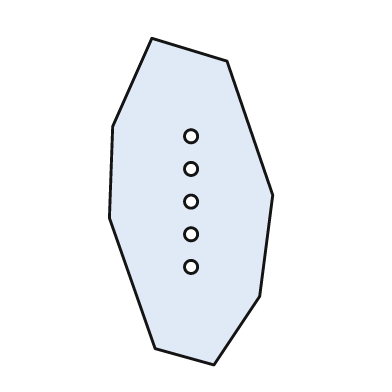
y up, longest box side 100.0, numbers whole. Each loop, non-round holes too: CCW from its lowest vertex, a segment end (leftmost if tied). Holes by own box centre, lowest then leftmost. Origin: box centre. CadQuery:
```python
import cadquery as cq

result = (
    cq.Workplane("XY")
    .moveTo(7.0, -50.0)
    .lineTo(21.0, -29.0)
    .lineTo(25.0, 2.0)
    .lineTo(11.0, 43.0)
    .lineTo(-12.0, 50.0)
    .lineTo(-24.0, 23.0)
    .lineTo(-25.0, -5.0)
    .lineTo(-11.0, -45.0)
    .close()
    .moveTo(0.0, -20.0)
    .circle(2.0)
    .moveTo(0.0, -10.0)
    .circle(2.0)
    .moveTo(0.0, 0.0)
    .circle(2.0)
    .moveTo(0.0, 10.0)
    .circle(2.0)
    .moveTo(0.0, 20.0)
    .circle(2.0)
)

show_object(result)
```